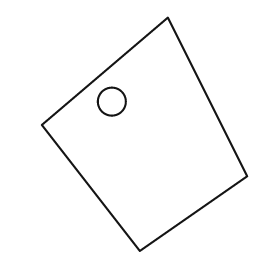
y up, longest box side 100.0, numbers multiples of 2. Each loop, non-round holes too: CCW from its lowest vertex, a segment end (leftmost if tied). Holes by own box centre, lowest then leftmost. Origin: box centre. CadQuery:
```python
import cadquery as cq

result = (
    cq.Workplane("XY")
    .moveTo(-2.0, -50.0)
    .lineTo(44.0, -18.0)
    .lineTo(10.0, 50.0)
    .lineTo(-44.0, 4.0)
    .close()
    .moveTo(-14.0, 14.0)
    .circle(6.0)
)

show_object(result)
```